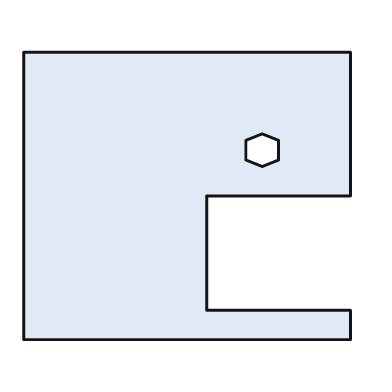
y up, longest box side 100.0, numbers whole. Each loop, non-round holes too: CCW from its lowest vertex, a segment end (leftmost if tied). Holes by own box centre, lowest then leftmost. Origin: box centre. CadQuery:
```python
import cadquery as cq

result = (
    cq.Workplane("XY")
    .moveTo(-50.0, -44.0)
    .lineTo(50.0, -44.0)
    .lineTo(50.0, -35.0)
    .lineTo(6.0, -35.0)
    .lineTo(6.0, 0.0)
    .lineTo(50.0, 0.0)
    .lineTo(50.0, 44.0)
    .lineTo(-50.0, 44.0)
    .close()
    .moveTo(23.0, 9.0)
    .lineTo(28.0, 11.0)
    .lineTo(28.0, 17.0)
    .lineTo(23.0, 19.0)
    .lineTo(18.0, 17.0)
    .lineTo(18.0, 11.0)
    .close()
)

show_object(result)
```